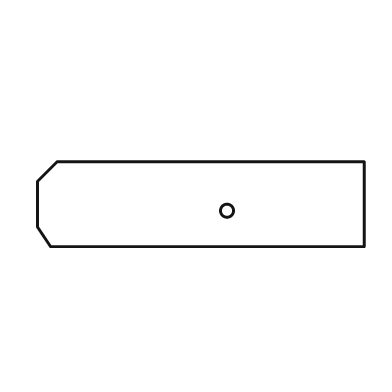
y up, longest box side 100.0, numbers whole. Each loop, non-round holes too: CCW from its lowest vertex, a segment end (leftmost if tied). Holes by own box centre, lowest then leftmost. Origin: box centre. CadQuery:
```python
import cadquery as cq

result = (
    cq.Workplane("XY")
    .moveTo(-46.0, -13.0)
    .lineTo(50.0, -13.0)
    .lineTo(50.0, 13.0)
    .lineTo(-44.0, 13.0)
    .lineTo(-50.0, 7.0)
    .lineTo(-50.0, -7.0)
    .close()
    .moveTo(8.0, -2.0)
    .circle(2.0)
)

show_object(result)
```